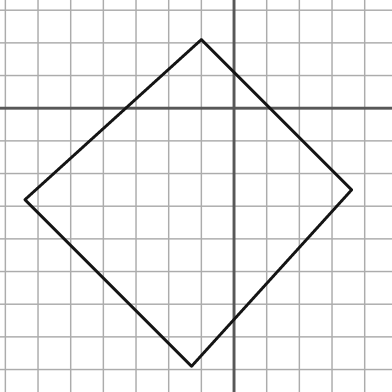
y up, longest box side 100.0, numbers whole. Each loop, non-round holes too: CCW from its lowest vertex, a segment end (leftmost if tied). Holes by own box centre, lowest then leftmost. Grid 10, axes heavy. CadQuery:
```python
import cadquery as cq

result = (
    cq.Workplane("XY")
    .moveTo(-13.0, -79.0)
    .lineTo(36.0, -25.0)
    .lineTo(-10.0, 21.0)
    .lineTo(-64.0, -28.0)
    .close()
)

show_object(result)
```